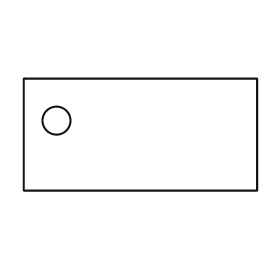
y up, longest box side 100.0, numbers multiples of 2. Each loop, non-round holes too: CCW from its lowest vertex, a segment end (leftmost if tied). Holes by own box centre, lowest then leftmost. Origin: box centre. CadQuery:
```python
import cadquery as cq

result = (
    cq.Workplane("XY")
    .moveTo(-50.0, -24.0)
    .lineTo(50.0, -24.0)
    .lineTo(50.0, 24.0)
    .lineTo(-50.0, 24.0)
    .close()
    .moveTo(-36.0, 6.0)
    .circle(6.0)
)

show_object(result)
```